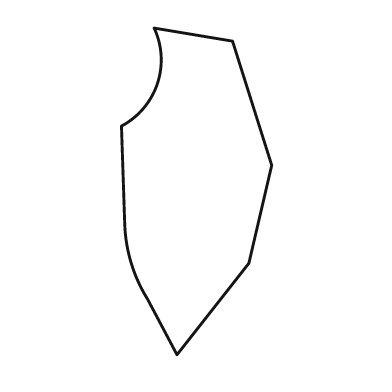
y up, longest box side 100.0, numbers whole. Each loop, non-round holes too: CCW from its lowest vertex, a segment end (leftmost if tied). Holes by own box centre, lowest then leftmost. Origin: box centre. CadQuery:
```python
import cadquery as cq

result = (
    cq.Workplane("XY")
    .moveTo(-6.0, -50.0)
    .lineTo(16.0, -22.0)
    .lineTo(23.0, 8.0)
    .lineTo(11.0, 46.0)
    .lineTo(-13.0, 50.0)
    .threePointArc((-12.0, 33.0), (-23.0, 20.0))
    .lineTo(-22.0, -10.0)
    .threePointArc((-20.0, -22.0), (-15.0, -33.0))
    .close()
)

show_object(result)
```